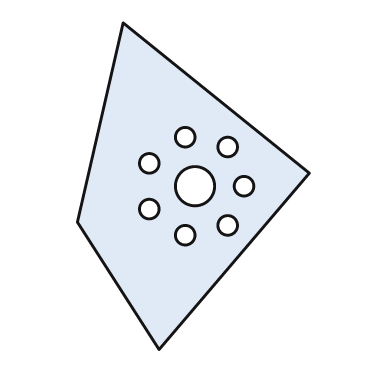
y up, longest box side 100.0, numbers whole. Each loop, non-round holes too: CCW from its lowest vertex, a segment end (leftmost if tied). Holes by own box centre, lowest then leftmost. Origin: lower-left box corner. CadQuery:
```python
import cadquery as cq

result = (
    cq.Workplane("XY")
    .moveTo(25.0, 0.0)
    .lineTo(71.0, 54.0)
    .lineTo(14.0, 100.0)
    .lineTo(0.0, 39.0)
    .close()
    .moveTo(33.0, 35.0)
    .circle(3.0)
    .moveTo(46.0, 38.0)
    .circle(3.0)
    .moveTo(22.0, 43.0)
    .circle(3.0)
    .moveTo(36.0, 50.0)
    .circle(6.0)
    .moveTo(51.0, 50.0)
    .circle(3.0)
    .moveTo(22.0, 57.0)
    .circle(3.0)
    .moveTo(46.0, 62.0)
    .circle(3.0)
    .moveTo(33.0, 65.0)
    .circle(3.0)
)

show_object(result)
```